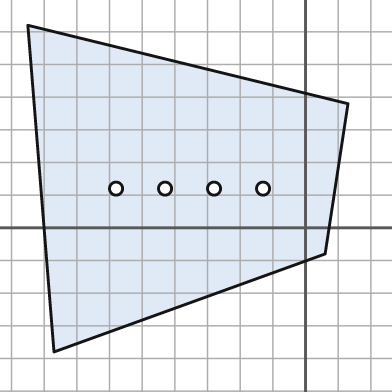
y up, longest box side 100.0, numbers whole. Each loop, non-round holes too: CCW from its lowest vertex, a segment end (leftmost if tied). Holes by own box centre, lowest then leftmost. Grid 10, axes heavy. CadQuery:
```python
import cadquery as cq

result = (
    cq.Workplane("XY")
    .moveTo(-77.0, -38.0)
    .lineTo(6.0, -8.0)
    .lineTo(13.0, 38.0)
    .lineTo(-85.0, 62.0)
    .close()
    .moveTo(-58.0, 12.0)
    .circle(2.0)
    .moveTo(-43.0, 12.0)
    .circle(2.0)
    .moveTo(-28.0, 12.0)
    .circle(2.0)
    .moveTo(-13.0, 12.0)
    .circle(2.0)
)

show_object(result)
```